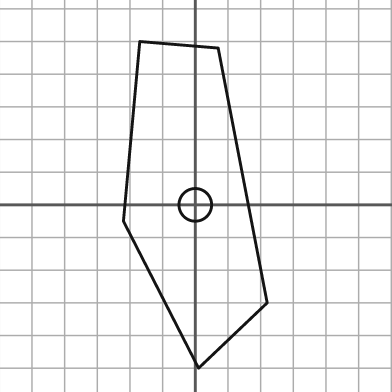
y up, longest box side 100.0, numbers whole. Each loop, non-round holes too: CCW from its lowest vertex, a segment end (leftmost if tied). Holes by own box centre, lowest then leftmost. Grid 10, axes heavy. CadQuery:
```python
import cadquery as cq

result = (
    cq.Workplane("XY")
    .moveTo(1.0, -50.0)
    .lineTo(22.0, -30.0)
    .lineTo(7.0, 48.0)
    .lineTo(-17.0, 50.0)
    .lineTo(-22.0, -5.0)
    .close()
    .moveTo(0.0, 0.0)
    .circle(5.0)
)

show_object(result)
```